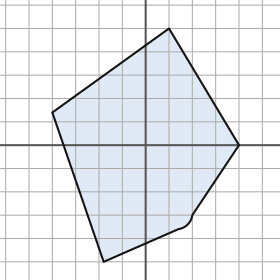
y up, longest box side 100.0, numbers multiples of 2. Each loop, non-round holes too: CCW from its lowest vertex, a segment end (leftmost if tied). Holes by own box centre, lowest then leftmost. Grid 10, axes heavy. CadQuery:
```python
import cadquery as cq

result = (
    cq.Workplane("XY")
    .moveTo(-18.0, -50.0)
    .lineTo(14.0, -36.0)
    .threePointArc((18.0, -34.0), (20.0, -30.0))
    .lineTo(40.0, 0.0)
    .lineTo(10.0, 50.0)
    .lineTo(-40.0, 14.0)
    .close()
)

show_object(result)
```